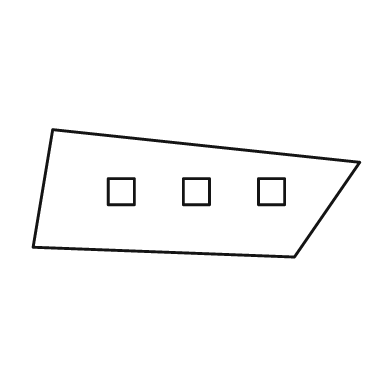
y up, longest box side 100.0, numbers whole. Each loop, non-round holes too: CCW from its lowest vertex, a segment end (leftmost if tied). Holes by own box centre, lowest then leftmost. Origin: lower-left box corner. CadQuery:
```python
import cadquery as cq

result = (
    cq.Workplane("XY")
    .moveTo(80.0, 0.0)
    .lineTo(100.0, 29.0)
    .lineTo(6.0, 39.0)
    .lineTo(0.0, 3.0)
    .close()
    .moveTo(23.0, 16.0)
    .lineTo(31.0, 16.0)
    .lineTo(31.0, 24.0)
    .lineTo(23.0, 24.0)
    .close()
    .moveTo(46.0, 16.0)
    .lineTo(54.0, 16.0)
    .lineTo(54.0, 24.0)
    .lineTo(46.0, 24.0)
    .close()
    .moveTo(69.0, 16.0)
    .lineTo(77.0, 16.0)
    .lineTo(77.0, 24.0)
    .lineTo(69.0, 24.0)
    .close()
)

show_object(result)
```